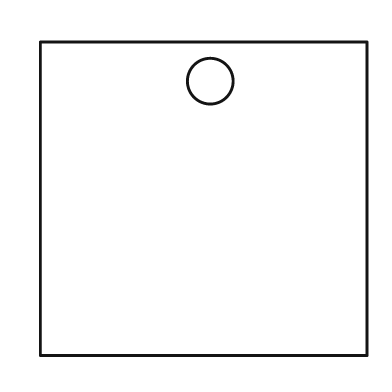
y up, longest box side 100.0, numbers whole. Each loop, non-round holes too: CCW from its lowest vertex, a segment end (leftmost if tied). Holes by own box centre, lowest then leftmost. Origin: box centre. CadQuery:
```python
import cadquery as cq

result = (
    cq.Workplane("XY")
    .moveTo(-50.0, -48.0)
    .lineTo(50.0, -48.0)
    .lineTo(50.0, 48.0)
    .lineTo(-50.0, 48.0)
    .close()
    .moveTo(2.0, 36.0)
    .circle(7.0)
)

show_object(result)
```